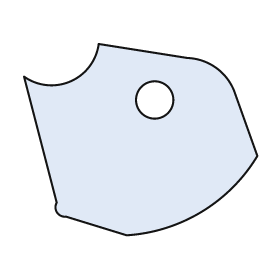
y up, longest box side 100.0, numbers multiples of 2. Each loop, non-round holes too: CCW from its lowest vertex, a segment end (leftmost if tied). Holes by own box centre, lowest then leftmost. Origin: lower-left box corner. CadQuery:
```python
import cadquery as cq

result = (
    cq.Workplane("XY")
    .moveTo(44.0, 0.0)
    .threePointArc((76.0, 10.0), (100.0, 34.0))
    .lineTo(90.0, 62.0)
    .threePointArc((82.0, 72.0), (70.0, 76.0))
    .lineTo(32.0, 82.0)
    .threePointArc((20.0, 66.0), (0.0, 68.0))
    .lineTo(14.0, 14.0)
    .threePointArc((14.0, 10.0), (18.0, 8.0))
    .close()
    .moveTo(56.0, 58.0)
    .circle(8.0)
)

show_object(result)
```